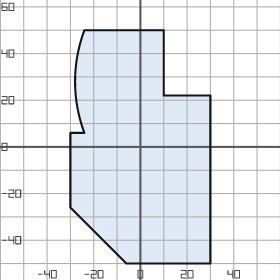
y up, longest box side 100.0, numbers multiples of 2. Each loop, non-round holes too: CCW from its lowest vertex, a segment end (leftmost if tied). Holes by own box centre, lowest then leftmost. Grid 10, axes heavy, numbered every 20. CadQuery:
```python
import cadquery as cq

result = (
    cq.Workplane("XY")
    .moveTo(-6.0, -50.0)
    .lineTo(30.0, -50.0)
    .lineTo(30.0, 22.0)
    .lineTo(10.0, 22.0)
    .lineTo(10.0, 50.0)
    .lineTo(-24.0, 50.0)
    .threePointArc((-28.0, 28.0), (-24.0, 6.0))
    .lineTo(-30.0, 6.0)
    .lineTo(-30.0, -26.0)
    .close()
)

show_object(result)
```